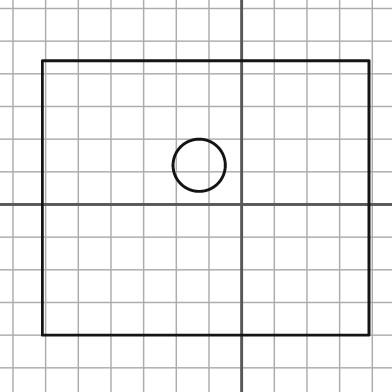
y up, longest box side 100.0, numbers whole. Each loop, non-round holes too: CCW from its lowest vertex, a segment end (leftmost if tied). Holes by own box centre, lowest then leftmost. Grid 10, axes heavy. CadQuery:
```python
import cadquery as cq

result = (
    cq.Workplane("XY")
    .moveTo(-61.0, -40.0)
    .lineTo(39.0, -40.0)
    .lineTo(39.0, 44.0)
    .lineTo(-61.0, 44.0)
    .close()
    .moveTo(-13.0, 12.0)
    .circle(8.0)
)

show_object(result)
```